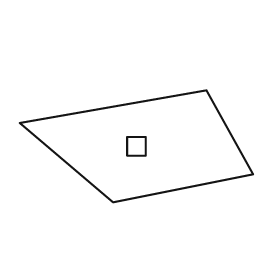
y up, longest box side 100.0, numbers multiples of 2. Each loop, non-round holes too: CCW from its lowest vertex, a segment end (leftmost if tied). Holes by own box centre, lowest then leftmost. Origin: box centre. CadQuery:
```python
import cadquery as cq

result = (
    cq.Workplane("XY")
    .moveTo(-10.0, -24.0)
    .lineTo(50.0, -12.0)
    .lineTo(30.0, 24.0)
    .lineTo(-50.0, 10.0)
    .close()
    .moveTo(-4.0, -4.0)
    .lineTo(4.0, -4.0)
    .lineTo(4.0, 4.0)
    .lineTo(-4.0, 4.0)
    .close()
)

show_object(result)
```